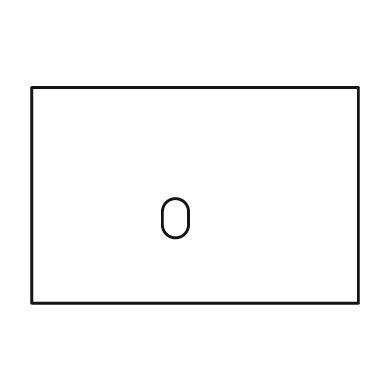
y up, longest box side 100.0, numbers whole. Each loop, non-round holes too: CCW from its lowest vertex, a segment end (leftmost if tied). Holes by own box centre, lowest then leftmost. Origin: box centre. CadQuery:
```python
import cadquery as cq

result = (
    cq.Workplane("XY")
    .moveTo(-50.0, -33.0)
    .lineTo(50.0, -33.0)
    .lineTo(50.0, 33.0)
    .lineTo(-50.0, 33.0)
    .close()
    .moveTo(-10.0, -9.0)
    .threePointArc((-6.0, -13.0), (-2.0, -9.0))
    .lineTo(-2.0, -5.0)
    .threePointArc((-6.0, -1.0), (-10.0, -5.0))
    .close()
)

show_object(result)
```